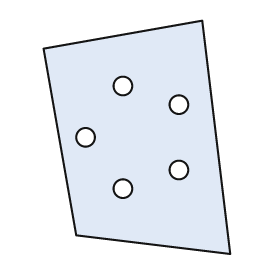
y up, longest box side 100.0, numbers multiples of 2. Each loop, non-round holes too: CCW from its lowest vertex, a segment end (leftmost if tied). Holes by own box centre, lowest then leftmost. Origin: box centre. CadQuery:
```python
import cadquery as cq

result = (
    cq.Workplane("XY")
    .moveTo(40.0, -50.0)
    .lineTo(28.0, 50.0)
    .lineTo(-40.0, 38.0)
    .lineTo(-26.0, -42.0)
    .close()
    .moveTo(-6.0, -22.0)
    .circle(4.0)
    .moveTo(18.0, -14.0)
    .circle(4.0)
    .moveTo(-22.0, 0.0)
    .circle(4.0)
    .moveTo(18.0, 14.0)
    .circle(4.0)
    .moveTo(-6.0, 22.0)
    .circle(4.0)
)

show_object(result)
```